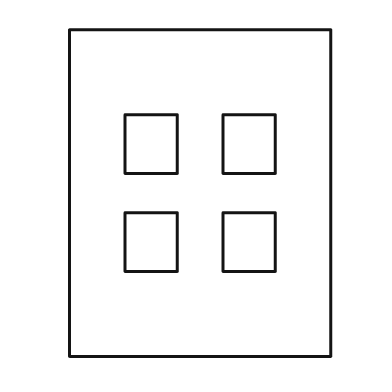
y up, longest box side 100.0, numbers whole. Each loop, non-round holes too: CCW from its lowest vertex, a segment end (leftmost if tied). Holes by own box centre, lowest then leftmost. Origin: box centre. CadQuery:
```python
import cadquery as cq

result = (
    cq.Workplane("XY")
    .moveTo(-40.0, -50.0)
    .lineTo(40.0, -50.0)
    .lineTo(40.0, 50.0)
    .lineTo(-40.0, 50.0)
    .close()
    .moveTo(-23.0, -24.0)
    .lineTo(-7.0, -24.0)
    .lineTo(-7.0, -6.0)
    .lineTo(-23.0, -6.0)
    .close()
    .moveTo(7.0, -24.0)
    .lineTo(23.0, -24.0)
    .lineTo(23.0, -6.0)
    .lineTo(7.0, -6.0)
    .close()
    .moveTo(-23.0, 6.0)
    .lineTo(-7.0, 6.0)
    .lineTo(-7.0, 24.0)
    .lineTo(-23.0, 24.0)
    .close()
    .moveTo(7.0, 6.0)
    .lineTo(23.0, 6.0)
    .lineTo(23.0, 24.0)
    .lineTo(7.0, 24.0)
    .close()
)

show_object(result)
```